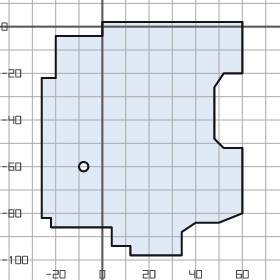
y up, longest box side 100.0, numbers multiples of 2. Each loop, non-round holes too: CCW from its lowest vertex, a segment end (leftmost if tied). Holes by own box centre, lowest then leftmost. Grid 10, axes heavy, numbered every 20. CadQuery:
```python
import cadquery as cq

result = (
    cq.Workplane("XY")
    .moveTo(12.0, -98.0)
    .lineTo(34.0, -98.0)
    .lineTo(34.0, -88.0)
    .lineTo(40.0, -84.0)
    .lineTo(50.0, -84.0)
    .lineTo(60.0, -80.0)
    .lineTo(60.0, -52.0)
    .lineTo(52.0, -52.0)
    .lineTo(48.0, -48.0)
    .lineTo(48.0, -26.0)
    .lineTo(52.0, -20.0)
    .lineTo(60.0, -20.0)
    .lineTo(60.0, 2.0)
    .lineTo(0.0, 2.0)
    .lineTo(0.0, -4.0)
    .lineTo(-20.0, -4.0)
    .lineTo(-20.0, -22.0)
    .lineTo(-26.0, -22.0)
    .lineTo(-26.0, -82.0)
    .lineTo(-22.0, -82.0)
    .lineTo(-22.0, -86.0)
    .lineTo(4.0, -86.0)
    .lineTo(4.0, -94.0)
    .lineTo(12.0, -94.0)
    .close()
    .moveTo(-8.0, -60.0)
    .circle(2.0)
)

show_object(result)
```